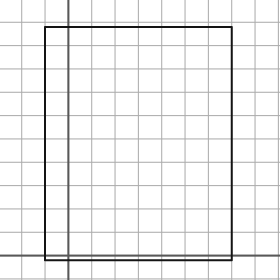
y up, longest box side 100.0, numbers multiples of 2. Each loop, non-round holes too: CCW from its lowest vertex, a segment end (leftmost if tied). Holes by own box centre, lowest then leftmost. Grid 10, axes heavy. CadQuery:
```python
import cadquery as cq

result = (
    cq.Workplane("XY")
    .moveTo(-10.0, -2.0)
    .lineTo(70.0, -2.0)
    .lineTo(70.0, 98.0)
    .lineTo(-10.0, 98.0)
    .close()
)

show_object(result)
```